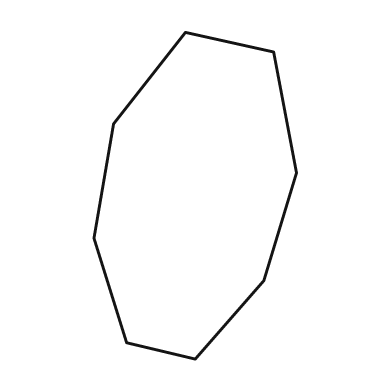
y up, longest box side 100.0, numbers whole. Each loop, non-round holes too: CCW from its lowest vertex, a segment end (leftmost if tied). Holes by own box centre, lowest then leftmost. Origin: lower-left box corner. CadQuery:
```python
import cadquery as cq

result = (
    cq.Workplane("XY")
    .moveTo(31.0, 0.0)
    .lineTo(52.0, 24.0)
    .lineTo(62.0, 57.0)
    .lineTo(55.0, 94.0)
    .lineTo(28.0, 100.0)
    .lineTo(6.0, 72.0)
    .lineTo(0.0, 37.0)
    .lineTo(10.0, 5.0)
    .close()
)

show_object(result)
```